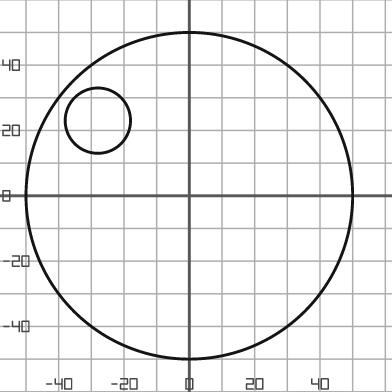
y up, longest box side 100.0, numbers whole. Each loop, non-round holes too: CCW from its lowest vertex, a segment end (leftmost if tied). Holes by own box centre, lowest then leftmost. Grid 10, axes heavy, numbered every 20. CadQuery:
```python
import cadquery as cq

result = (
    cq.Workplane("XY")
    .moveTo(0.0, 0.0)
    .circle(50.0)
    .moveTo(-28.0, 23.0)
    .circle(10.0)
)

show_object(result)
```